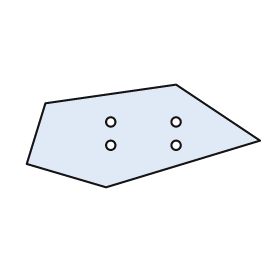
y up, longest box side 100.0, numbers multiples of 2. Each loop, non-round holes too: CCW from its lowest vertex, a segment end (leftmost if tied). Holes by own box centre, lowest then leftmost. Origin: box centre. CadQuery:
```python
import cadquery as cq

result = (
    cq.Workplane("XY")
    .moveTo(-16.0, -22.0)
    .lineTo(50.0, -2.0)
    .lineTo(14.0, 22.0)
    .lineTo(-42.0, 14.0)
    .lineTo(-50.0, -12.0)
    .close()
    .moveTo(-14.0, -4.0)
    .circle(2.0)
    .moveTo(14.0, -4.0)
    .circle(2.0)
    .moveTo(-14.0, 6.0)
    .circle(2.0)
    .moveTo(14.0, 6.0)
    .circle(2.0)
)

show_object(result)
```